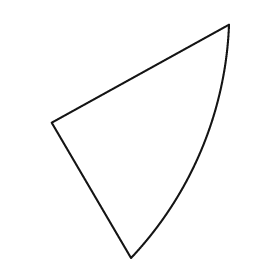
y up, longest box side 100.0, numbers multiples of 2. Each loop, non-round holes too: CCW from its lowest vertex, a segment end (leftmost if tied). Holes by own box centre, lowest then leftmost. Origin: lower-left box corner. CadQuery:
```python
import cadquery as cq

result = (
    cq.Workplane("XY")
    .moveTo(34.0, 0.0)
    .threePointArc((64.0, 46.0), (76.0, 100.0))
    .lineTo(0.0, 58.0)
    .close()
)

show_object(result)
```